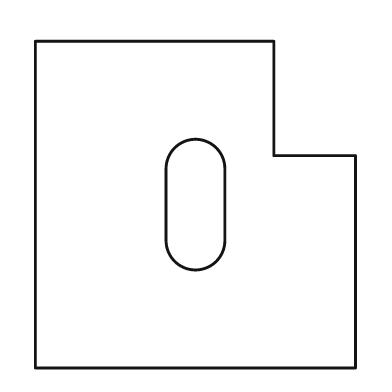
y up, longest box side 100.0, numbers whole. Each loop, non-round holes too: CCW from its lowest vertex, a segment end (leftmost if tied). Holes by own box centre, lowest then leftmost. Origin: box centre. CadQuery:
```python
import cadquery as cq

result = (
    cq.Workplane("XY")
    .moveTo(-49.0, -50.0)
    .lineTo(49.0, -50.0)
    .lineTo(49.0, 15.0)
    .lineTo(24.0, 15.0)
    .lineTo(24.0, 50.0)
    .lineTo(-49.0, 50.0)
    .close()
    .moveTo(-9.0, -11.0)
    .threePointArc((0.0, -20.0), (9.0, -11.0))
    .lineTo(9.0, 11.0)
    .threePointArc((0.0, 20.0), (-9.0, 11.0))
    .close()
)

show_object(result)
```